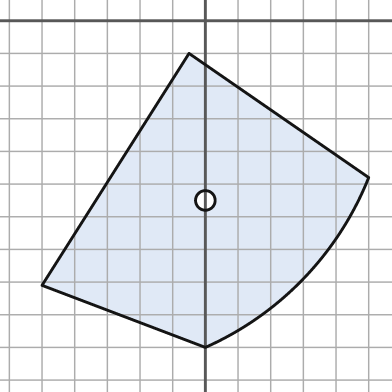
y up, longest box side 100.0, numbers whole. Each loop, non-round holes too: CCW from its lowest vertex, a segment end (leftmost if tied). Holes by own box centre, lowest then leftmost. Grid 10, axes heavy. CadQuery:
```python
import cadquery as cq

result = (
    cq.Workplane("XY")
    .moveTo(0.0, -100.0)
    .threePointArc((30.0, -79.0), (50.0, -48.0))
    .lineTo(-5.0, -10.0)
    .lineTo(-50.0, -81.0)
    .close()
    .moveTo(0.0, -55.0)
    .circle(3.0)
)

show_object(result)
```